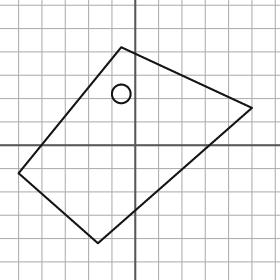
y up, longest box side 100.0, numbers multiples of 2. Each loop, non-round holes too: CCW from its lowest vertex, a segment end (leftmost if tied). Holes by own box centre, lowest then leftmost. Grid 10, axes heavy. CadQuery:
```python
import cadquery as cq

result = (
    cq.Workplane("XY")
    .moveTo(-16.0, -42.0)
    .lineTo(50.0, 16.0)
    .lineTo(-6.0, 42.0)
    .lineTo(-50.0, -12.0)
    .close()
    .moveTo(-6.0, 22.0)
    .circle(4.0)
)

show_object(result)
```